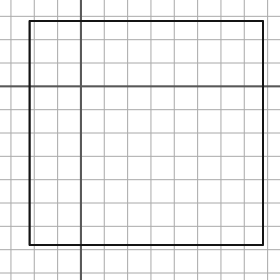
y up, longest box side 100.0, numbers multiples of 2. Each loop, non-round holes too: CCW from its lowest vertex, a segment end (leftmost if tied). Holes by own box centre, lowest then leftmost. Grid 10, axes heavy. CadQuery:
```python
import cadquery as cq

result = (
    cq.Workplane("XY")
    .moveTo(-22.0, -68.0)
    .lineTo(78.0, -68.0)
    .lineTo(78.0, 28.0)
    .lineTo(-22.0, 28.0)
    .close()
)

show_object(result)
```